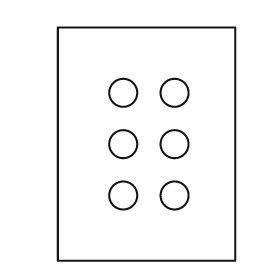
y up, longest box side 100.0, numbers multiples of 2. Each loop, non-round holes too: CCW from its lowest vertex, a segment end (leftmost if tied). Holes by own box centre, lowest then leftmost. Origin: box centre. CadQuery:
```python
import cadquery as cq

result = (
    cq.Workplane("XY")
    .moveTo(-38.0, -50.0)
    .lineTo(38.0, -50.0)
    .lineTo(38.0, 50.0)
    .lineTo(-38.0, 50.0)
    .close()
    .moveTo(-10.0, -22.0)
    .circle(6.0)
    .moveTo(12.0, -22.0)
    .circle(6.0)
    .moveTo(-10.0, 0.0)
    .circle(6.0)
    .moveTo(12.0, 0.0)
    .circle(6.0)
    .moveTo(-10.0, 22.0)
    .circle(6.0)
    .moveTo(12.0, 22.0)
    .circle(6.0)
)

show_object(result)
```